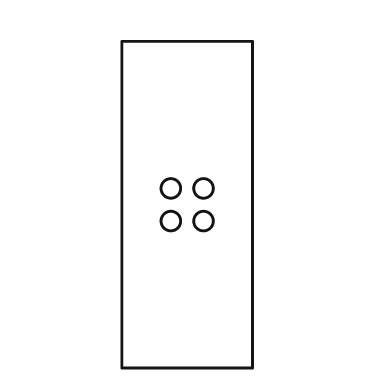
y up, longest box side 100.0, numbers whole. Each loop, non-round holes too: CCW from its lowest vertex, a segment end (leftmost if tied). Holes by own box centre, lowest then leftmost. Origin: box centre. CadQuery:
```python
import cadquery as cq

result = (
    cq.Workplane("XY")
    .moveTo(-20.0, -50.0)
    .lineTo(20.0, -50.0)
    .lineTo(20.0, 50.0)
    .lineTo(-20.0, 50.0)
    .close()
    .moveTo(-5.0, -5.0)
    .circle(3.0)
    .moveTo(5.0, -5.0)
    .circle(3.0)
    .moveTo(-5.0, 5.0)
    .circle(3.0)
    .moveTo(5.0, 5.0)
    .circle(3.0)
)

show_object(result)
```